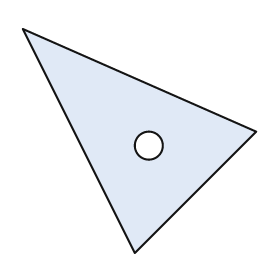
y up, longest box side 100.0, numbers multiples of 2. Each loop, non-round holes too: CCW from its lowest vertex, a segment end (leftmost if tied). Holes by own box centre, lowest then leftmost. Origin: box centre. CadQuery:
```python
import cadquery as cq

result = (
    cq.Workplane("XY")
    .moveTo(-2.0, -48.0)
    .lineTo(50.0, 4.0)
    .lineTo(-50.0, 48.0)
    .close()
    .moveTo(4.0, -2.0)
    .circle(6.0)
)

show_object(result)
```